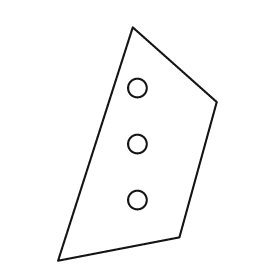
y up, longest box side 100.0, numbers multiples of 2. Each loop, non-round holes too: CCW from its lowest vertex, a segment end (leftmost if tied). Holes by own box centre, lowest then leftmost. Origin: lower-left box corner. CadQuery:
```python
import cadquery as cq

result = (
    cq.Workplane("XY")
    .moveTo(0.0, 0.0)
    .lineTo(52.0, 10.0)
    .lineTo(68.0, 68.0)
    .lineTo(32.0, 100.0)
    .close()
    .moveTo(34.0, 26.0)
    .circle(4.0)
    .moveTo(34.0, 50.0)
    .circle(4.0)
    .moveTo(34.0, 74.0)
    .circle(4.0)
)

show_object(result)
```